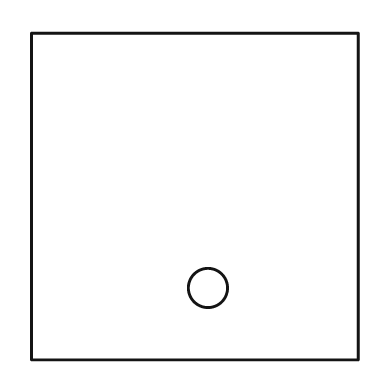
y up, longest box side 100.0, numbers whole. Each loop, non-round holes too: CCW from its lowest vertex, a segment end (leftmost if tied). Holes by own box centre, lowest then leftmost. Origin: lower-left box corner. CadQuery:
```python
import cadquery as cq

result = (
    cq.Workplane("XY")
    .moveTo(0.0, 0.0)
    .lineTo(100.0, 0.0)
    .lineTo(100.0, 100.0)
    .lineTo(0.0, 100.0)
    .close()
    .moveTo(54.0, 22.0)
    .circle(6.0)
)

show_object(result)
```